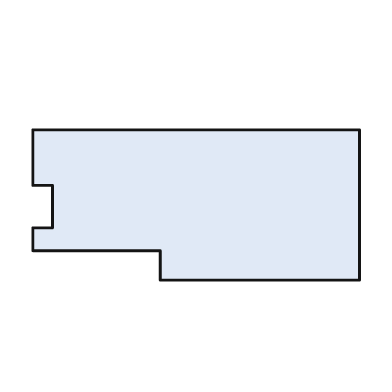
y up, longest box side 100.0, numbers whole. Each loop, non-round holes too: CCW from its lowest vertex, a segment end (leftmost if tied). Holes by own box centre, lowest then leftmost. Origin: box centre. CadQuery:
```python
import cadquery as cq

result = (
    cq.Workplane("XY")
    .moveTo(-11.0, -23.0)
    .lineTo(50.0, -23.0)
    .lineTo(50.0, 23.0)
    .lineTo(-50.0, 23.0)
    .lineTo(-50.0, 6.0)
    .lineTo(-44.0, 6.0)
    .lineTo(-44.0, -7.0)
    .lineTo(-50.0, -7.0)
    .lineTo(-50.0, -14.0)
    .lineTo(-11.0, -14.0)
    .close()
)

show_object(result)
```